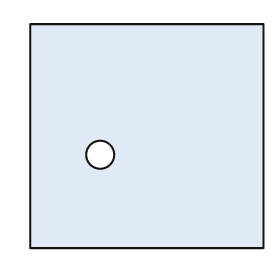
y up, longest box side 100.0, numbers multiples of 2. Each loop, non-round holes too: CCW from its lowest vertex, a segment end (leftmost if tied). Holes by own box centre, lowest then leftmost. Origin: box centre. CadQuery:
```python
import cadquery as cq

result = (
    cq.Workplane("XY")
    .moveTo(-50.0, -48.0)
    .lineTo(50.0, -48.0)
    .lineTo(50.0, 48.0)
    .lineTo(-50.0, 48.0)
    .close()
    .moveTo(-20.0, -8.0)
    .circle(6.0)
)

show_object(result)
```